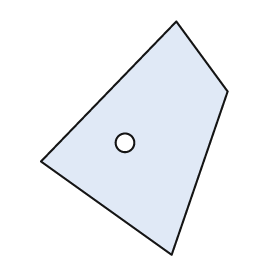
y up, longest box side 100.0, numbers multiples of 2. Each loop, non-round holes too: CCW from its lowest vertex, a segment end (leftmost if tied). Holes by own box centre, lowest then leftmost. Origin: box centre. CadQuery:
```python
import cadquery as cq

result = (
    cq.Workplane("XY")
    .moveTo(16.0, -50.0)
    .lineTo(40.0, 20.0)
    .lineTo(18.0, 50.0)
    .lineTo(-40.0, -10.0)
    .close()
    .moveTo(-4.0, -2.0)
    .circle(4.0)
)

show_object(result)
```